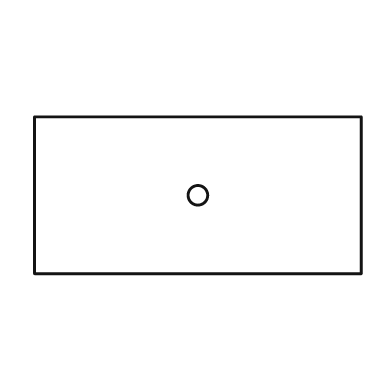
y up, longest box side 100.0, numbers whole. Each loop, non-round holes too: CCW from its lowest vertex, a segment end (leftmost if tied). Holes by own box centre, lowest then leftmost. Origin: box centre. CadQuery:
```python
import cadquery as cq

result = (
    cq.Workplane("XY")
    .moveTo(-50.0, -24.0)
    .lineTo(50.0, -24.0)
    .lineTo(50.0, 24.0)
    .lineTo(-50.0, 24.0)
    .close()
    .moveTo(0.0, 0.0)
    .circle(3.0)
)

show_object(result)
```